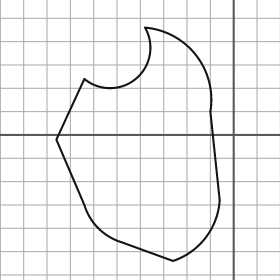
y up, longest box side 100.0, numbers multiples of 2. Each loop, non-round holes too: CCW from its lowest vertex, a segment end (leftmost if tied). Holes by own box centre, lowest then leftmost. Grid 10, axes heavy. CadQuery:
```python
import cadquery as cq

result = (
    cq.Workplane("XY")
    .moveTo(-26.0, -54.0)
    .threePointArc((-12.0, -44.0), (-6.0, -28.0))
    .lineTo(-10.0, 10.0)
    .threePointArc((-16.0, 34.0), (-38.0, 46.0))
    .threePointArc((-42.0, 24.0), (-64.0, 24.0))
    .lineTo(-76.0, -2.0)
    .lineTo(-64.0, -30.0)
    .threePointArc((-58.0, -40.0), (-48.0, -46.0))
    .close()
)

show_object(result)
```